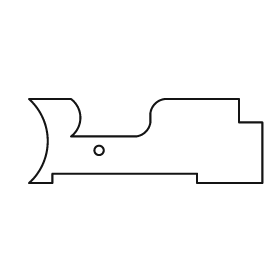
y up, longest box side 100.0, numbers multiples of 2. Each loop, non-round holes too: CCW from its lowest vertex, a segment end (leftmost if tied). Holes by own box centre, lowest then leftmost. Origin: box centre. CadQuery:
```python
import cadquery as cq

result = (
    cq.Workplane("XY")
    .moveTo(-50.0, -18.0)
    .lineTo(-40.0, -18.0)
    .lineTo(-40.0, -14.0)
    .lineTo(22.0, -14.0)
    .lineTo(22.0, -18.0)
    .lineTo(50.0, -18.0)
    .lineTo(50.0, 8.0)
    .lineTo(40.0, 8.0)
    .lineTo(40.0, 18.0)
    .lineTo(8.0, 18.0)
    .threePointArc((4.0, 16.0), (2.0, 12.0))
    .lineTo(2.0, 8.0)
    .threePointArc((0.0, 4.0), (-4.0, 2.0))
    .lineTo(-32.0, 2.0)
    .threePointArc((-28.0, 10.0), (-32.0, 18.0))
    .lineTo(-50.0, 18.0)
    .threePointArc((-42.0, 0.0), (-50.0, -18.0))
    .close()
    .moveTo(-20.0, -4.0)
    .circle(2.0)
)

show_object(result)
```